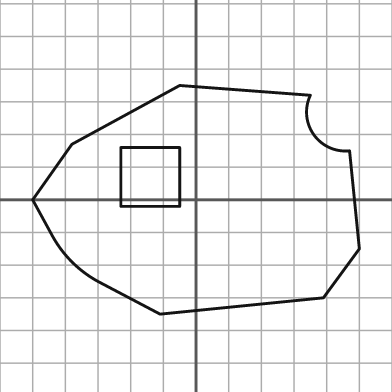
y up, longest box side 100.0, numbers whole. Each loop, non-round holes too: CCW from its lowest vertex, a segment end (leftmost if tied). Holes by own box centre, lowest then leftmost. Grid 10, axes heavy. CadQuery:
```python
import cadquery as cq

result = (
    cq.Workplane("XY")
    .moveTo(-11.0, -35.0)
    .lineTo(39.0, -30.0)
    .lineTo(50.0, -15.0)
    .lineTo(47.0, 15.0)
    .threePointArc((36.0, 20.0), (35.0, 32.0))
    .lineTo(-5.0, 35.0)
    .lineTo(-38.0, 17.0)
    .lineTo(-50.0, 0.0)
    .lineTo(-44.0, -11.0)
    .threePointArc((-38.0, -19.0), (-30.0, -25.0))
    .close()
    .moveTo(-23.0, -2.0)
    .lineTo(-5.0, -2.0)
    .lineTo(-5.0, 16.0)
    .lineTo(-23.0, 16.0)
    .close()
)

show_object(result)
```